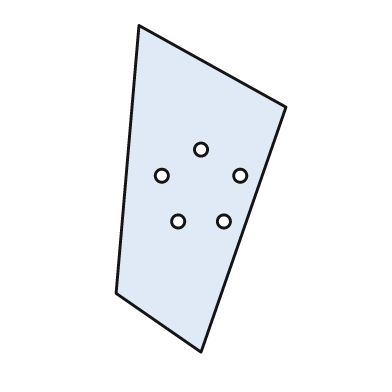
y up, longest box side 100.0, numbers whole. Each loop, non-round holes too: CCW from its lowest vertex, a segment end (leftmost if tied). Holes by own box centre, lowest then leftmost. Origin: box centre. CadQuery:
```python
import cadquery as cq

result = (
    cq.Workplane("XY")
    .moveTo(0.0, -50.0)
    .lineTo(26.0, 25.0)
    .lineTo(-19.0, 50.0)
    .lineTo(-26.0, -32.0)
    .close()
    .moveTo(-7.0, -10.0)
    .circle(2.0)
    .moveTo(7.0, -10.0)
    .circle(2.0)
    .moveTo(-12.0, 4.0)
    .circle(2.0)
    .moveTo(12.0, 4.0)
    .circle(2.0)
    .moveTo(0.0, 12.0)
    .circle(2.0)
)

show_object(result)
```